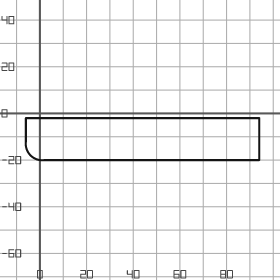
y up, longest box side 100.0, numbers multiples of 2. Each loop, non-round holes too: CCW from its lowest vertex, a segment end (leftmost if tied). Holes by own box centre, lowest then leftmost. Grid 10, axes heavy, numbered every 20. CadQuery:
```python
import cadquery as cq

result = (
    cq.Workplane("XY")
    .moveTo(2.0, -20.0)
    .lineTo(94.0, -20.0)
    .lineTo(94.0, -2.0)
    .lineTo(-6.0, -2.0)
    .lineTo(-6.0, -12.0)
    .threePointArc((-4.0, -18.0), (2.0, -20.0))
    .close()
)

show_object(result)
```